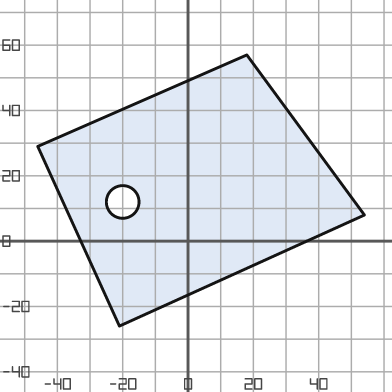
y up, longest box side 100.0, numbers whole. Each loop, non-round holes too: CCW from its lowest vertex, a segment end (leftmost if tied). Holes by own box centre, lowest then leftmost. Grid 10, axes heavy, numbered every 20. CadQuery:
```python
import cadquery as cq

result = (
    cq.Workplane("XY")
    .moveTo(-21.0, -26.0)
    .lineTo(54.0, 8.0)
    .lineTo(18.0, 57.0)
    .lineTo(-46.0, 29.0)
    .close()
    .moveTo(-20.0, 12.0)
    .circle(5.0)
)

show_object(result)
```